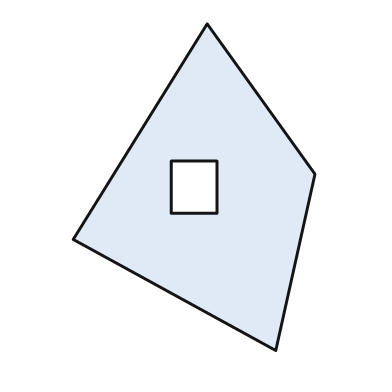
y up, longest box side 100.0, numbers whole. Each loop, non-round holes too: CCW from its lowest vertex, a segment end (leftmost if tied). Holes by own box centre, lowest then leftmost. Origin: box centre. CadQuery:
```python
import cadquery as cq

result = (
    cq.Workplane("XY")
    .moveTo(25.0, -50.0)
    .lineTo(37.0, 4.0)
    .lineTo(4.0, 50.0)
    .lineTo(-37.0, -16.0)
    .close()
    .moveTo(-7.0, -8.0)
    .lineTo(7.0, -8.0)
    .lineTo(7.0, 8.0)
    .lineTo(-7.0, 8.0)
    .close()
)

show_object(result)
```